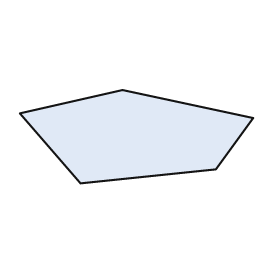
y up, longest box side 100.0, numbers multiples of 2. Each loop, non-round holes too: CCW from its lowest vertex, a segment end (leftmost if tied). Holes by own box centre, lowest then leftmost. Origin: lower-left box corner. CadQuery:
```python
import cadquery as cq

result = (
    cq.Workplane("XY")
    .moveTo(26.0, 0.0)
    .lineTo(84.0, 6.0)
    .lineTo(100.0, 28.0)
    .lineTo(44.0, 40.0)
    .lineTo(0.0, 30.0)
    .close()
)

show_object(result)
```